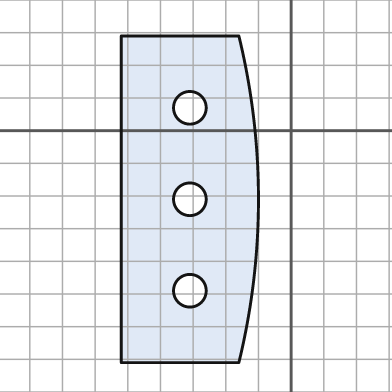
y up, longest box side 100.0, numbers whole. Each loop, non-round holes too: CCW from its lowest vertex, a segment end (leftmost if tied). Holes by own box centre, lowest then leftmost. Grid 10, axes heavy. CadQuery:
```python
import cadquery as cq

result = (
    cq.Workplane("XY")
    .moveTo(-52.0, -71.0)
    .lineTo(-16.0, -71.0)
    .threePointArc((-10.0, -21.0), (-16.0, 29.0))
    .lineTo(-52.0, 29.0)
    .close()
    .moveTo(-31.0, -49.0)
    .circle(5.0)
    .moveTo(-31.0, -21.0)
    .circle(5.0)
    .moveTo(-31.0, 7.0)
    .circle(5.0)
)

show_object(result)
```